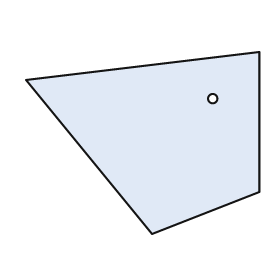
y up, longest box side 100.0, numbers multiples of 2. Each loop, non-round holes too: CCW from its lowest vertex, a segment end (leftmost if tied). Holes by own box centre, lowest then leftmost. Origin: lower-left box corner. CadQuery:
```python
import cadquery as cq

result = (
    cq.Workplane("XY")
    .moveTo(54.0, 0.0)
    .lineTo(100.0, 18.0)
    .lineTo(100.0, 78.0)
    .lineTo(0.0, 66.0)
    .close()
    .moveTo(80.0, 58.0)
    .circle(2.0)
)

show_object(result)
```